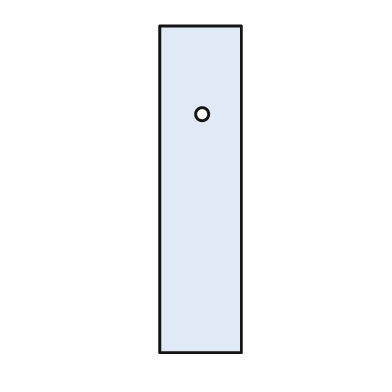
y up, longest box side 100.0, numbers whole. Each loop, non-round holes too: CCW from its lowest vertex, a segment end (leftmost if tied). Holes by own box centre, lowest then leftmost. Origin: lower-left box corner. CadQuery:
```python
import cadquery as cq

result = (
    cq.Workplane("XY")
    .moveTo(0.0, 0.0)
    .lineTo(25.0, 0.0)
    .lineTo(25.0, 100.0)
    .lineTo(0.0, 100.0)
    .close()
    .moveTo(13.0, 73.0)
    .circle(2.0)
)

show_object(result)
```